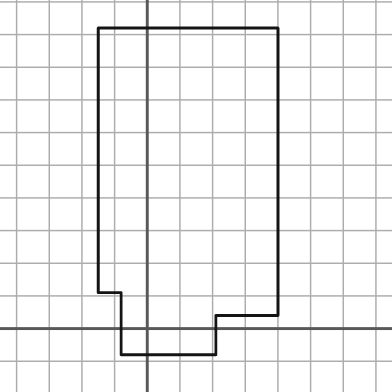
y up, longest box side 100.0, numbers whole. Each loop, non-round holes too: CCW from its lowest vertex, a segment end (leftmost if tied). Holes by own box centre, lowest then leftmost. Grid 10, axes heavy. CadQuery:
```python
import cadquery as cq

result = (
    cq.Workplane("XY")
    .moveTo(-8.0, -8.0)
    .lineTo(21.0, -8.0)
    .lineTo(21.0, 4.0)
    .lineTo(40.0, 4.0)
    .lineTo(40.0, 92.0)
    .lineTo(-15.0, 92.0)
    .lineTo(-15.0, 11.0)
    .lineTo(-8.0, 11.0)
    .close()
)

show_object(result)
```